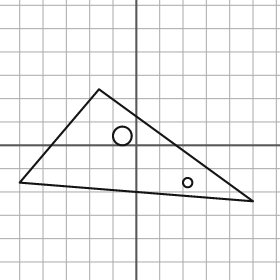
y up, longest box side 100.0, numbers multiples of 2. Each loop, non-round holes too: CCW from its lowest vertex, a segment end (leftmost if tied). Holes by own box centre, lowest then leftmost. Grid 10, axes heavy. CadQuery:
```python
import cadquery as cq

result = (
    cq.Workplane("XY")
    .moveTo(50.0, -24.0)
    .lineTo(-16.0, 24.0)
    .lineTo(-50.0, -16.0)
    .close()
    .moveTo(22.0, -16.0)
    .circle(2.0)
    .moveTo(-6.0, 4.0)
    .circle(4.0)
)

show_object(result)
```